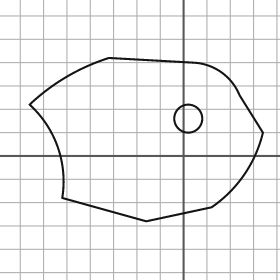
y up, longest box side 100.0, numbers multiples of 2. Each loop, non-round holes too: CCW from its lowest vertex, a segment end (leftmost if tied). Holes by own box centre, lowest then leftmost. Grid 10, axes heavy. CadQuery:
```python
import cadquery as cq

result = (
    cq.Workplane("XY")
    .moveTo(-16.0, -28.0)
    .lineTo(12.0, -22.0)
    .threePointArc((26.0, -8.0), (34.0, 10.0))
    .lineTo(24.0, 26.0)
    .threePointArc((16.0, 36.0), (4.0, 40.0))
    .lineTo(-32.0, 42.0)
    .threePointArc((-50.0, 34.0), (-66.0, 22.0))
    .threePointArc((-54.0, 4.0), (-52.0, -18.0))
    .close()
    .moveTo(2.0, 16.0)
    .circle(6.0)
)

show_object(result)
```